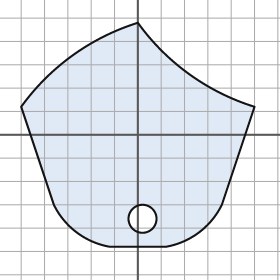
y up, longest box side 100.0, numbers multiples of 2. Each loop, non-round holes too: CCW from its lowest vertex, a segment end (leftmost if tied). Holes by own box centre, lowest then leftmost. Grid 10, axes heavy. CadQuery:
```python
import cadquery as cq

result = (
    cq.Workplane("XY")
    .moveTo(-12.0, -48.0)
    .lineTo(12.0, -48.0)
    .threePointArc((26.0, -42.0), (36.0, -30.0))
    .lineTo(50.0, 12.0)
    .threePointArc((22.0, 26.0), (0.0, 48.0))
    .threePointArc((-28.0, 34.0), (-50.0, 12.0))
    .lineTo(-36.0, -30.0)
    .threePointArc((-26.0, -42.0), (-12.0, -48.0))
    .close()
    .moveTo(2.0, -36.0)
    .circle(6.0)
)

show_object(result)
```